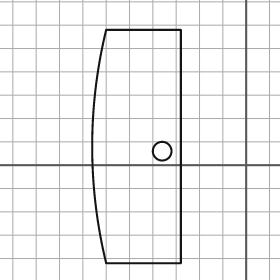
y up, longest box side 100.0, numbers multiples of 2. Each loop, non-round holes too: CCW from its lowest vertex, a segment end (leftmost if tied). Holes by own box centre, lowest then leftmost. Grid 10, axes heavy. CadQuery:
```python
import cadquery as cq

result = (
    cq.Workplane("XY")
    .moveTo(-60.0, -42.0)
    .lineTo(-28.0, -42.0)
    .lineTo(-28.0, 58.0)
    .lineTo(-60.0, 58.0)
    .threePointArc((-66.0, 8.0), (-60.0, -42.0))
    .close()
    .moveTo(-36.0, 6.0)
    .circle(4.0)
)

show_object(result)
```